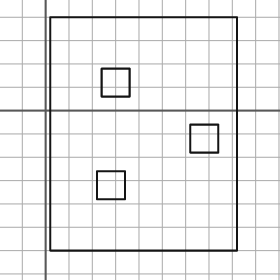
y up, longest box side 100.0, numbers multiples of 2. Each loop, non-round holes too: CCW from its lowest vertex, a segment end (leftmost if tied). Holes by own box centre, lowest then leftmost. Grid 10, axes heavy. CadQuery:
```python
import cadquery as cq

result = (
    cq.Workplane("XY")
    .moveTo(2.0, -60.0)
    .lineTo(82.0, -60.0)
    .lineTo(82.0, 40.0)
    .lineTo(2.0, 40.0)
    .close()
    .moveTo(22.0, -38.0)
    .lineTo(34.0, -38.0)
    .lineTo(34.0, -26.0)
    .lineTo(22.0, -26.0)
    .close()
    .moveTo(62.0, -18.0)
    .lineTo(74.0, -18.0)
    .lineTo(74.0, -6.0)
    .lineTo(62.0, -6.0)
    .close()
    .moveTo(24.0, 6.0)
    .lineTo(36.0, 6.0)
    .lineTo(36.0, 18.0)
    .lineTo(24.0, 18.0)
    .close()
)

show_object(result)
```